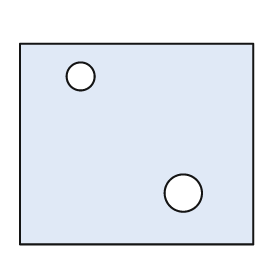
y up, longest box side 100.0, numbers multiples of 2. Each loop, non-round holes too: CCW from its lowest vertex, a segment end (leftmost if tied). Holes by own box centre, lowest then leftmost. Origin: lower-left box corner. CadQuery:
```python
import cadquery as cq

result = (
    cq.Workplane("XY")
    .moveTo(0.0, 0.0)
    .lineTo(100.0, 0.0)
    .lineTo(100.0, 86.0)
    .lineTo(0.0, 86.0)
    .close()
    .moveTo(70.0, 22.0)
    .circle(8.0)
    .moveTo(26.0, 72.0)
    .circle(6.0)
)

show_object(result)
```